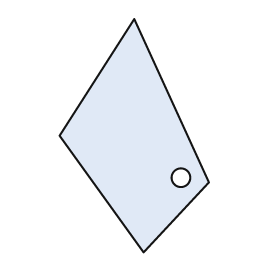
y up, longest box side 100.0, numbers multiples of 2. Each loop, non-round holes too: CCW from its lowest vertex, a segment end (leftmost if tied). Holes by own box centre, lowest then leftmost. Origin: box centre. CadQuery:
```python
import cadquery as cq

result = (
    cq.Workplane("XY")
    .moveTo(4.0, -50.0)
    .lineTo(32.0, -20.0)
    .lineTo(0.0, 50.0)
    .lineTo(-32.0, 0.0)
    .close()
    .moveTo(20.0, -18.0)
    .circle(4.0)
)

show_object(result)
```